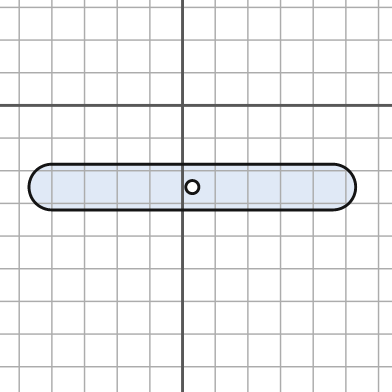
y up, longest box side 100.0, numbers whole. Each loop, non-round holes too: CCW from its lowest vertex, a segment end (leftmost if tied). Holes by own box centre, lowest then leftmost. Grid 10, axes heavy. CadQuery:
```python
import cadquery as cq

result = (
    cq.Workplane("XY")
    .moveTo(-40.0, -32.0)
    .lineTo(46.0, -32.0)
    .threePointArc((53.0, -25.0), (46.0, -18.0))
    .lineTo(-40.0, -18.0)
    .threePointArc((-47.0, -25.0), (-40.0, -32.0))
    .close()
    .moveTo(3.0, -25.0)
    .circle(2.0)
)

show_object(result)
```